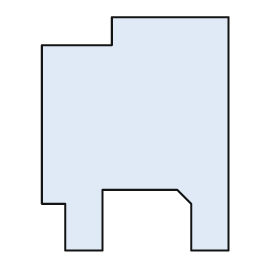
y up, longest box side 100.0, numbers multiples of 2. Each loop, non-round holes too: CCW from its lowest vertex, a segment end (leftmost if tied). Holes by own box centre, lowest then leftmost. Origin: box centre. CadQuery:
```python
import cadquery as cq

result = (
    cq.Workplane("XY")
    .moveTo(-30.0, -50.0)
    .lineTo(-14.0, -50.0)
    .lineTo(-14.0, -24.0)
    .lineTo(18.0, -24.0)
    .lineTo(24.0, -30.0)
    .lineTo(24.0, -50.0)
    .lineTo(40.0, -50.0)
    .lineTo(40.0, 50.0)
    .lineTo(-10.0, 50.0)
    .lineTo(-10.0, 38.0)
    .lineTo(-40.0, 38.0)
    .lineTo(-40.0, -30.0)
    .lineTo(-30.0, -30.0)
    .close()
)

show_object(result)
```